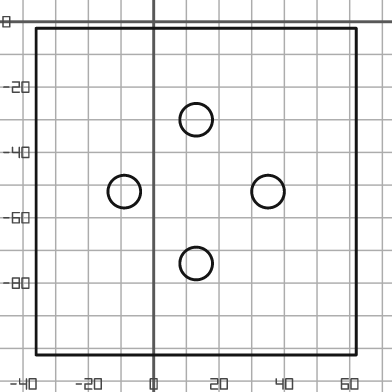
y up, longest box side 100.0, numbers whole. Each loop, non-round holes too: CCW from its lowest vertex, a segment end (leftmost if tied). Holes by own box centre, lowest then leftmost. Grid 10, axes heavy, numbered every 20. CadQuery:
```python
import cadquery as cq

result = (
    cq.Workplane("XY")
    .moveTo(-36.0, -102.0)
    .lineTo(62.0, -102.0)
    .lineTo(62.0, -2.0)
    .lineTo(-36.0, -2.0)
    .close()
    .moveTo(13.0, -74.0)
    .circle(5.0)
    .moveTo(-9.0, -52.0)
    .circle(5.0)
    .moveTo(35.0, -52.0)
    .circle(5.0)
    .moveTo(13.0, -30.0)
    .circle(5.0)
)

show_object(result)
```